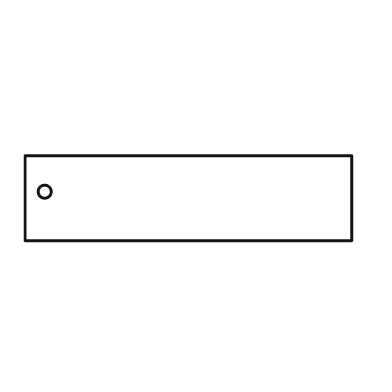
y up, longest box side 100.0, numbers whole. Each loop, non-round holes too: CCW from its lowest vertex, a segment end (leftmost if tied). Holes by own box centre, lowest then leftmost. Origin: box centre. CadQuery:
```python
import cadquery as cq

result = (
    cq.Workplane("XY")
    .moveTo(-50.0, -13.0)
    .lineTo(50.0, -13.0)
    .lineTo(50.0, 13.0)
    .lineTo(-50.0, 13.0)
    .close()
    .moveTo(-44.0, 2.0)
    .circle(2.0)
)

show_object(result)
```